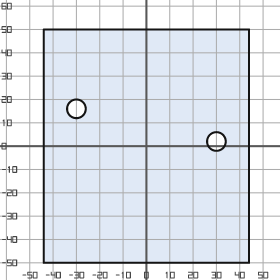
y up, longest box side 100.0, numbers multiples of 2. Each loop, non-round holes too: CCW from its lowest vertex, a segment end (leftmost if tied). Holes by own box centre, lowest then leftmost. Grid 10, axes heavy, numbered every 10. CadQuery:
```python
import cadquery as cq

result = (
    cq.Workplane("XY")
    .moveTo(-44.0, -50.0)
    .lineTo(44.0, -50.0)
    .lineTo(44.0, 50.0)
    .lineTo(-44.0, 50.0)
    .close()
    .moveTo(30.0, 2.0)
    .circle(4.0)
    .moveTo(-30.0, 16.0)
    .circle(4.0)
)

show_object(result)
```